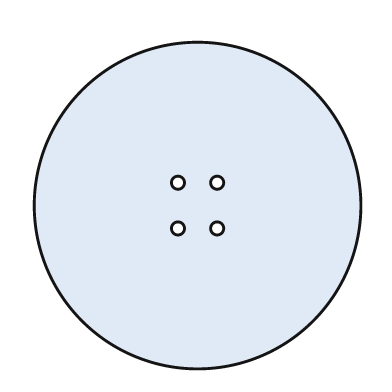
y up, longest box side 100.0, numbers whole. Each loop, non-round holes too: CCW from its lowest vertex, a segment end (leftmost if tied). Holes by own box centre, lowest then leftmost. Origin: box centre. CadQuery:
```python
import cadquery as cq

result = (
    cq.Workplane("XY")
    .moveTo(0.0, 0.0)
    .circle(50.0)
    .moveTo(-6.0, -7.0)
    .circle(2.0)
    .moveTo(6.0, -7.0)
    .circle(2.0)
    .moveTo(-6.0, 7.0)
    .circle(2.0)
    .moveTo(6.0, 7.0)
    .circle(2.0)
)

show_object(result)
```